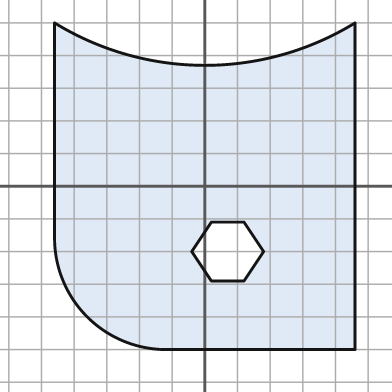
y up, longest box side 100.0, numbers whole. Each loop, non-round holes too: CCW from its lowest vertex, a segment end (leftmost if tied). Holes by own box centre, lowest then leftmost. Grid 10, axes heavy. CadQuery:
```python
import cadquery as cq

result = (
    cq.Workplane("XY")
    .moveTo(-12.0, -50.0)
    .lineTo(46.0, -50.0)
    .lineTo(46.0, 50.0)
    .threePointArc((0.0, 37.0), (-46.0, 50.0))
    .lineTo(-46.0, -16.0)
    .threePointArc((-36.0, -40.0), (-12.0, -50.0))
    .close()
    .moveTo(2.0, -29.0)
    .lineTo(12.0, -29.0)
    .lineTo(18.0, -20.0)
    .lineTo(12.0, -11.0)
    .lineTo(2.0, -11.0)
    .lineTo(-4.0, -20.0)
    .close()
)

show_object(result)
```